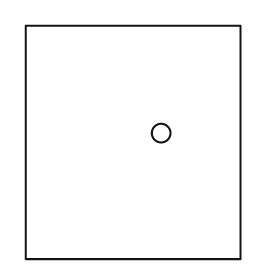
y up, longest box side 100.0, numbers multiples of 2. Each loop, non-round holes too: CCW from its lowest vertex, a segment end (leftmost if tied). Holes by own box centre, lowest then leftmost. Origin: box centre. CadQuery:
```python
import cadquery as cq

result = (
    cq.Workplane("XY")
    .moveTo(-46.0, -50.0)
    .lineTo(46.0, -50.0)
    .lineTo(46.0, 50.0)
    .lineTo(-46.0, 50.0)
    .close()
    .moveTo(12.0, 4.0)
    .circle(4.0)
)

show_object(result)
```